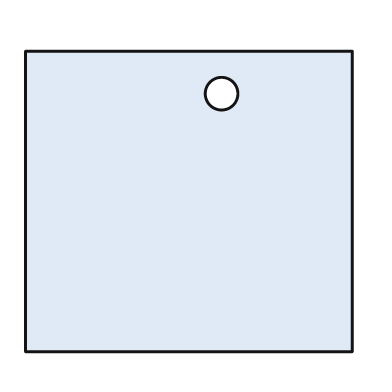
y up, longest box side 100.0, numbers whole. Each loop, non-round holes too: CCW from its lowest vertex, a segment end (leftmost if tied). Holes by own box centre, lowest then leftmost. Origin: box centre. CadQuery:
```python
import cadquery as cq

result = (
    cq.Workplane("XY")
    .moveTo(-50.0, -46.0)
    .lineTo(50.0, -46.0)
    .lineTo(50.0, 46.0)
    .lineTo(-50.0, 46.0)
    .close()
    .moveTo(10.0, 33.0)
    .circle(5.0)
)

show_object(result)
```